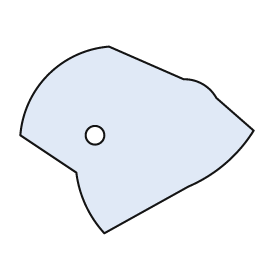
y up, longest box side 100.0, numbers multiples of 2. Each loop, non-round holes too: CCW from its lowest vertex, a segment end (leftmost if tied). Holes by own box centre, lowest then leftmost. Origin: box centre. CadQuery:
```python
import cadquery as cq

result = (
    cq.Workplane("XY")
    .moveTo(-14.0, -40.0)
    .lineTo(22.0, -20.0)
    .threePointArc((38.0, -10.0), (50.0, 4.0))
    .lineTo(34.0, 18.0)
    .threePointArc((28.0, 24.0), (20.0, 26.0))
    .lineTo(-12.0, 40.0)
    .threePointArc((-38.0, 28.0), (-50.0, 2.0))
    .lineTo(-26.0, -14.0)
    .threePointArc((-22.0, -28.0), (-14.0, -40.0))
    .close()
    .moveTo(-18.0, 2.0)
    .circle(4.0)
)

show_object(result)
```